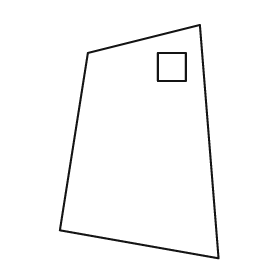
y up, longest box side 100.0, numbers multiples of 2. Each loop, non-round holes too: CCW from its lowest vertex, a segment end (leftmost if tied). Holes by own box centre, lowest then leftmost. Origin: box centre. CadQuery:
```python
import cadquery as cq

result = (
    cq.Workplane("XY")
    .moveTo(34.0, -50.0)
    .lineTo(26.0, 50.0)
    .lineTo(-22.0, 38.0)
    .lineTo(-34.0, -38.0)
    .close()
    .moveTo(8.0, 26.0)
    .lineTo(20.0, 26.0)
    .lineTo(20.0, 38.0)
    .lineTo(8.0, 38.0)
    .close()
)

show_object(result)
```